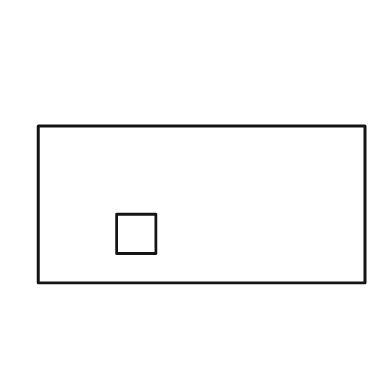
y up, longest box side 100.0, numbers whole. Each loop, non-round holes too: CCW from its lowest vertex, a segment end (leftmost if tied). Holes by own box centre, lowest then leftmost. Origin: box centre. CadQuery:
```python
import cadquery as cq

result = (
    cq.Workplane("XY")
    .moveTo(-50.0, -24.0)
    .lineTo(50.0, -24.0)
    .lineTo(50.0, 24.0)
    .lineTo(-50.0, 24.0)
    .close()
    .moveTo(-26.0, -15.0)
    .lineTo(-14.0, -15.0)
    .lineTo(-14.0, -3.0)
    .lineTo(-26.0, -3.0)
    .close()
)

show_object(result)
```